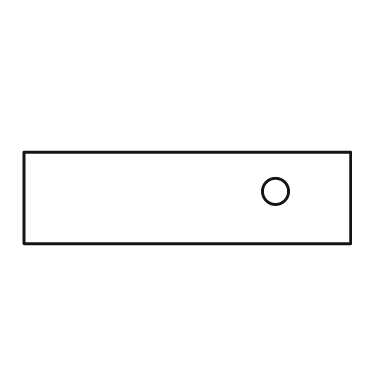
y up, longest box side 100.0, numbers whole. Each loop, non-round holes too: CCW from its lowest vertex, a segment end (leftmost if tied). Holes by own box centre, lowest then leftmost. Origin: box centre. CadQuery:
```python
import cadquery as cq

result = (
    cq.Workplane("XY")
    .moveTo(-50.0, -14.0)
    .lineTo(50.0, -14.0)
    .lineTo(50.0, 14.0)
    .lineTo(-50.0, 14.0)
    .close()
    .moveTo(27.0, 2.0)
    .circle(4.0)
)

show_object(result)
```